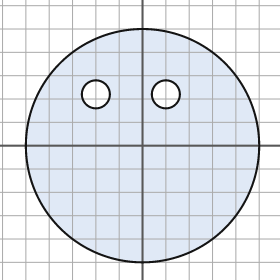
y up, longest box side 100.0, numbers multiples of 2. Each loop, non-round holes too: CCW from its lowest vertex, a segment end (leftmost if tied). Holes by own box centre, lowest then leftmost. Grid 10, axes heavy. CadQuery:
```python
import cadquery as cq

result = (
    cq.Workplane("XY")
    .moveTo(0.0, 0.0)
    .circle(50.0)
    .moveTo(-20.0, 22.0)
    .circle(6.0)
    .moveTo(10.0, 22.0)
    .circle(6.0)
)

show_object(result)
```